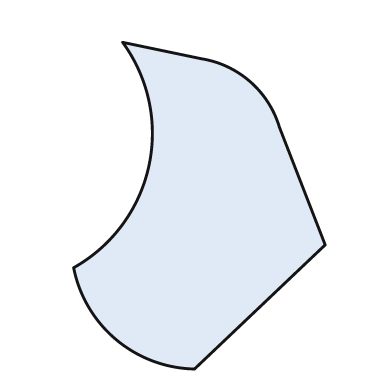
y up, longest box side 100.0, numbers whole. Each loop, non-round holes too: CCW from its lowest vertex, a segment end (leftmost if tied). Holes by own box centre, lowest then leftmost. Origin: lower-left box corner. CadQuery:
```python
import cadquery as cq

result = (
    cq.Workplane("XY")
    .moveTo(37.0, 0.0)
    .lineTo(77.0, 38.0)
    .lineTo(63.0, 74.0)
    .threePointArc((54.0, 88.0), (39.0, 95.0))
    .lineTo(15.0, 100.0)
    .threePointArc((23.0, 62.0), (0.0, 31.0))
    .threePointArc((13.0, 9.0), (37.0, 0.0))
    .close()
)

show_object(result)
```